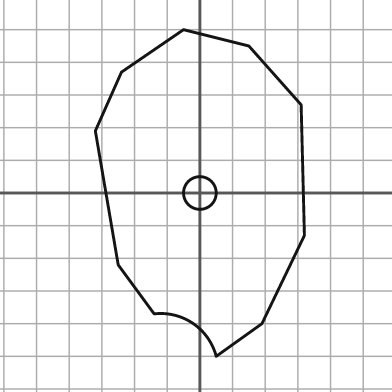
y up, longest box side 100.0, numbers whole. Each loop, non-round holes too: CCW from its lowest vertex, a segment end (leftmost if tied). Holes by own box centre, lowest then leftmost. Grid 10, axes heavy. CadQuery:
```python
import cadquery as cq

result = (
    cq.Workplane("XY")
    .moveTo(5.0, -50.0)
    .lineTo(19.0, -40.0)
    .lineTo(32.0, -13.0)
    .lineTo(31.0, 27.0)
    .lineTo(15.0, 45.0)
    .lineTo(-5.0, 50.0)
    .lineTo(-24.0, 37.0)
    .lineTo(-32.0, 19.0)
    .lineTo(-25.0, -22.0)
    .lineTo(-14.0, -37.0)
    .threePointArc((-2.0, -40.0), (5.0, -50.0))
    .close()
    .moveTo(0.0, 0.0)
    .circle(5.0)
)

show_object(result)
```